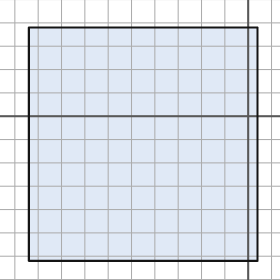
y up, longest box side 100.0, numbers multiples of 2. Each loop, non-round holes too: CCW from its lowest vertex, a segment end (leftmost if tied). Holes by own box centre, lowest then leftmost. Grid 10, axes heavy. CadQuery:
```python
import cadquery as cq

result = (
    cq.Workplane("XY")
    .moveTo(-94.0, -62.0)
    .lineTo(4.0, -62.0)
    .lineTo(4.0, 38.0)
    .lineTo(-94.0, 38.0)
    .close()
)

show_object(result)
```